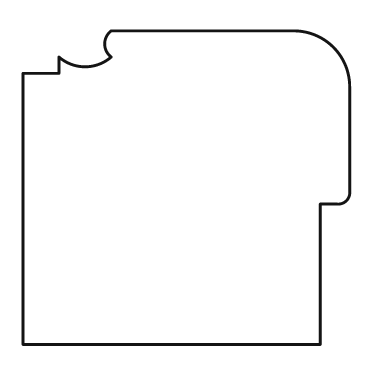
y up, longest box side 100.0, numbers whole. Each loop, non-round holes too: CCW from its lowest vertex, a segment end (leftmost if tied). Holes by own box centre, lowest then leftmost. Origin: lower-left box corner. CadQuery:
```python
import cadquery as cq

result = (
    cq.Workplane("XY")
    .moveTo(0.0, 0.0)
    .lineTo(91.0, 0.0)
    .lineTo(91.0, 43.0)
    .lineTo(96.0, 43.0)
    .threePointArc((99.0, 44.0), (100.0, 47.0))
    .lineTo(100.0, 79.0)
    .threePointArc((95.0, 91.0), (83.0, 96.0))
    .lineTo(27.0, 96.0)
    .threePointArc((25.0, 92.0), (27.0, 88.0))
    .threePointArc((19.0, 85.0), (11.0, 88.0))
    .lineTo(11.0, 83.0)
    .lineTo(0.0, 83.0)
    .close()
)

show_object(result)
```